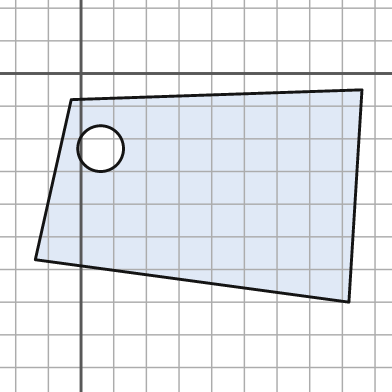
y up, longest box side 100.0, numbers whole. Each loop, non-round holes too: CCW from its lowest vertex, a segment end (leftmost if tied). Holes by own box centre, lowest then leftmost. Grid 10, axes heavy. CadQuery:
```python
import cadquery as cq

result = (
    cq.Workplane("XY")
    .moveTo(82.0, -70.0)
    .lineTo(86.0, -5.0)
    .lineTo(-3.0, -8.0)
    .lineTo(-14.0, -57.0)
    .close()
    .moveTo(6.0, -23.0)
    .circle(7.0)
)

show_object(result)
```